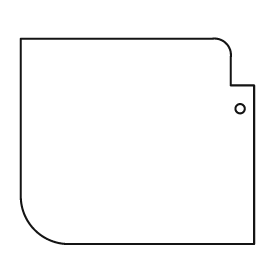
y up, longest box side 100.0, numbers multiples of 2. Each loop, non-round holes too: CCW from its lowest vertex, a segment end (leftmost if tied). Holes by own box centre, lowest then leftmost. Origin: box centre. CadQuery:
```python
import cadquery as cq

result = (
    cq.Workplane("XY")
    .moveTo(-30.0, -44.0)
    .lineTo(50.0, -44.0)
    .lineTo(50.0, 24.0)
    .lineTo(40.0, 24.0)
    .lineTo(40.0, 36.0)
    .threePointArc((38.0, 42.0), (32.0, 44.0))
    .lineTo(-50.0, 44.0)
    .lineTo(-50.0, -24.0)
    .threePointArc((-44.0, -38.0), (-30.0, -44.0))
    .close()
    .moveTo(44.0, 14.0)
    .circle(2.0)
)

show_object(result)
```